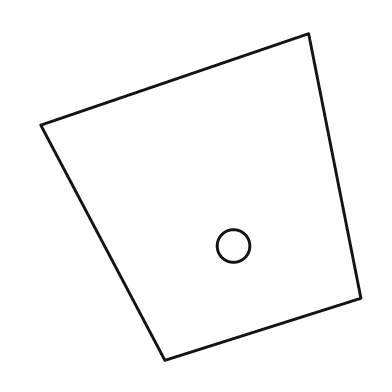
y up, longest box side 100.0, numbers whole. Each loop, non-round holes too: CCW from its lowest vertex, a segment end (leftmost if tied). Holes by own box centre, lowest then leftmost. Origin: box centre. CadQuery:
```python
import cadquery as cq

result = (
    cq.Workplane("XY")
    .moveTo(-11.0, -50.0)
    .lineTo(49.0, -31.0)
    .lineTo(33.0, 50.0)
    .lineTo(-49.0, 22.0)
    .close()
    .moveTo(10.0, -15.0)
    .circle(5.0)
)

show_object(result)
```